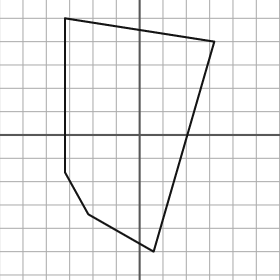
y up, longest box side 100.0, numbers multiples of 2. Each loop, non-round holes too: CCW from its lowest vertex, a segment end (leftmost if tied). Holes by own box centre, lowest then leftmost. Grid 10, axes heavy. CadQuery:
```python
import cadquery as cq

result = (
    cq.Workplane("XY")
    .moveTo(6.0, -50.0)
    .lineTo(32.0, 40.0)
    .lineTo(-32.0, 50.0)
    .lineTo(-32.0, -16.0)
    .lineTo(-22.0, -34.0)
    .close()
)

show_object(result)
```